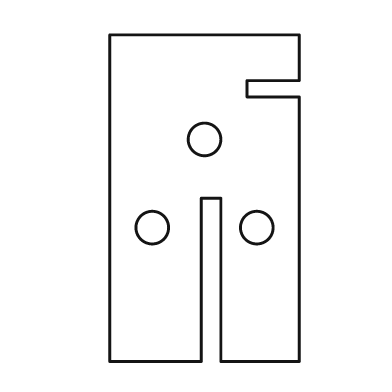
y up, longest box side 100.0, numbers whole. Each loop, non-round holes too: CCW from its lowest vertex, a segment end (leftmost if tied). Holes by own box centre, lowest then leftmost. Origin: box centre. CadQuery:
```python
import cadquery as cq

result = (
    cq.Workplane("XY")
    .moveTo(-29.0, -50.0)
    .lineTo(-1.0, -50.0)
    .lineTo(-1.0, 0.0)
    .lineTo(5.0, 0.0)
    .lineTo(5.0, -50.0)
    .lineTo(29.0, -50.0)
    .lineTo(29.0, 31.0)
    .lineTo(13.0, 31.0)
    .lineTo(13.0, 36.0)
    .lineTo(29.0, 36.0)
    .lineTo(29.0, 50.0)
    .lineTo(-29.0, 50.0)
    .close()
    .moveTo(-16.0, -9.0)
    .circle(5.0)
    .moveTo(16.0, -9.0)
    .circle(5.0)
    .moveTo(0.0, 18.0)
    .circle(5.0)
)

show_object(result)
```